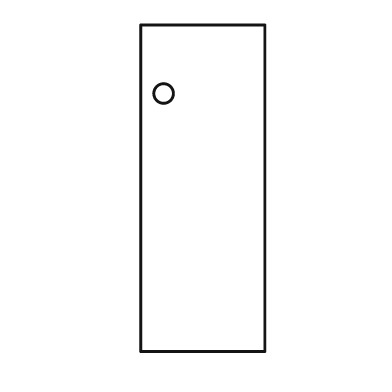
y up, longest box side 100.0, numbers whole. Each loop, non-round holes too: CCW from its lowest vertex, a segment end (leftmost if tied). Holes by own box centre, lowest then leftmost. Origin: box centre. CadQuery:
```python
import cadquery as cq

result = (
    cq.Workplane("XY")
    .moveTo(-19.0, -50.0)
    .lineTo(19.0, -50.0)
    .lineTo(19.0, 50.0)
    .lineTo(-19.0, 50.0)
    .close()
    .moveTo(-12.0, 29.0)
    .circle(3.0)
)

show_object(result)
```